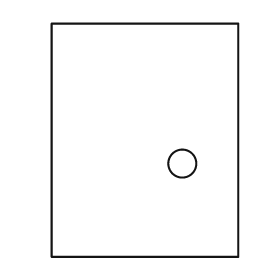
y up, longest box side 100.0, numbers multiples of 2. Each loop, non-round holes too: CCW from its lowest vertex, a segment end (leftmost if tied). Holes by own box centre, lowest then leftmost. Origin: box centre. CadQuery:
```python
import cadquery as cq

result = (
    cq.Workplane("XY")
    .moveTo(-40.0, -50.0)
    .lineTo(40.0, -50.0)
    .lineTo(40.0, 50.0)
    .lineTo(-40.0, 50.0)
    .close()
    .moveTo(16.0, -10.0)
    .circle(6.0)
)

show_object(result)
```